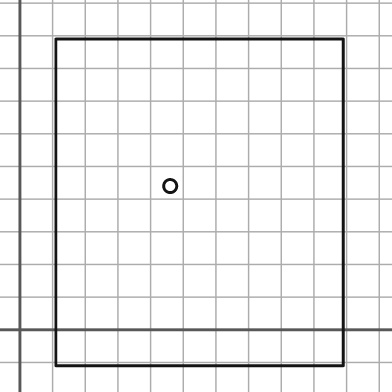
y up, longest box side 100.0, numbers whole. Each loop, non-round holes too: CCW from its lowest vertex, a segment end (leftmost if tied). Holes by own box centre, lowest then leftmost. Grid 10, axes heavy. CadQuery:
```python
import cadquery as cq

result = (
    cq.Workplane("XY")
    .moveTo(11.0, -11.0)
    .lineTo(99.0, -11.0)
    .lineTo(99.0, 89.0)
    .lineTo(11.0, 89.0)
    .close()
    .moveTo(46.0, 44.0)
    .circle(2.0)
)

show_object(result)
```